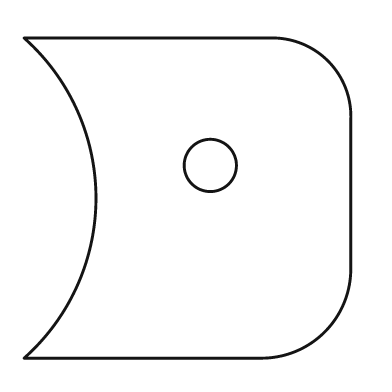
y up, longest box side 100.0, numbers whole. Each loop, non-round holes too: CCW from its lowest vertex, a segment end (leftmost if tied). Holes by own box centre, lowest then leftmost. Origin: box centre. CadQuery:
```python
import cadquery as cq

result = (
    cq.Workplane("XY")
    .moveTo(-50.0, -49.0)
    .lineTo(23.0, -49.0)
    .threePointArc((42.0, -41.0), (50.0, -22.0))
    .lineTo(50.0, 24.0)
    .threePointArc((43.0, 42.0), (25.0, 49.0))
    .lineTo(-50.0, 49.0)
    .threePointArc((-28.0, 0.0), (-50.0, -49.0))
    .close()
    .moveTo(7.0, 10.0)
    .circle(8.0)
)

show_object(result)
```